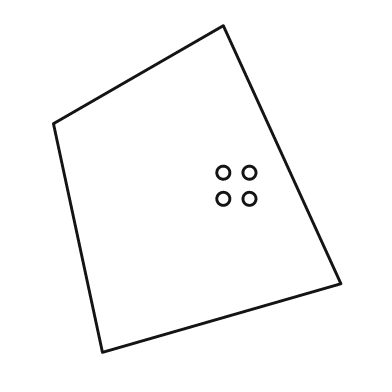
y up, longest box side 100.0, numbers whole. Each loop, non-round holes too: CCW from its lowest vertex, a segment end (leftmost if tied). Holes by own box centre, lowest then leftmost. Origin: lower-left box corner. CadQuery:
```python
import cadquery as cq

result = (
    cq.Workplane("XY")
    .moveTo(15.0, 0.0)
    .lineTo(88.0, 21.0)
    .lineTo(52.0, 100.0)
    .lineTo(0.0, 70.0)
    .close()
    .moveTo(52.0, 47.0)
    .circle(2.0)
    .moveTo(60.0, 47.0)
    .circle(2.0)
    .moveTo(52.0, 55.0)
    .circle(2.0)
    .moveTo(60.0, 55.0)
    .circle(2.0)
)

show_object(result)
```